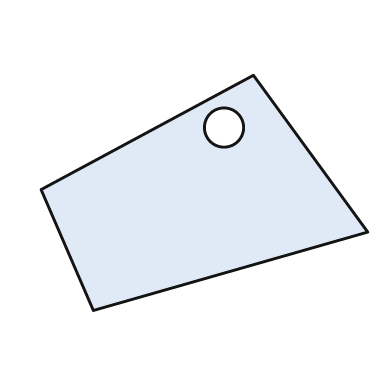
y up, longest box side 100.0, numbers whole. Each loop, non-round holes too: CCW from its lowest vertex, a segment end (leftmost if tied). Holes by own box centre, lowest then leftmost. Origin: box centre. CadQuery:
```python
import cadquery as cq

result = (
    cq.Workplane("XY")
    .moveTo(-34.0, -36.0)
    .lineTo(50.0, -12.0)
    .lineTo(15.0, 36.0)
    .lineTo(-50.0, 1.0)
    .close()
    .moveTo(6.0, 20.0)
    .circle(6.0)
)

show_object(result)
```